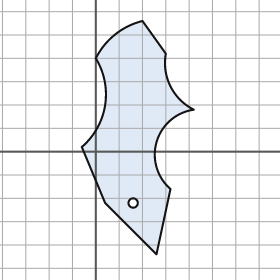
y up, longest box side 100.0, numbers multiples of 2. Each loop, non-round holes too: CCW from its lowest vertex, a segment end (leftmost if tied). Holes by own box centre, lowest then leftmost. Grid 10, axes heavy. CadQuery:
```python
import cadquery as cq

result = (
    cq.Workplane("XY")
    .moveTo(26.0, -44.0)
    .lineTo(32.0, -16.0)
    .threePointArc((26.0, 4.0), (42.0, 18.0))
    .threePointArc((32.0, 28.0), (30.0, 42.0))
    .lineTo(20.0, 56.0)
    .threePointArc((8.0, 50.0), (0.0, 40.0))
    .threePointArc((4.0, 20.0), (-6.0, 2.0))
    .lineTo(4.0, -22.0)
    .close()
    .moveTo(16.0, -22.0)
    .circle(2.0)
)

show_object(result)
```